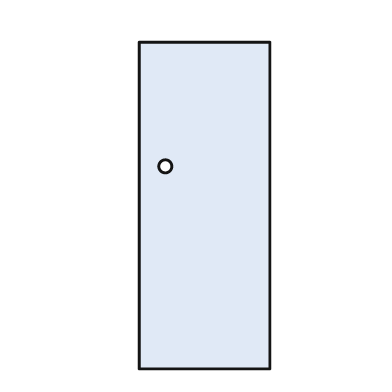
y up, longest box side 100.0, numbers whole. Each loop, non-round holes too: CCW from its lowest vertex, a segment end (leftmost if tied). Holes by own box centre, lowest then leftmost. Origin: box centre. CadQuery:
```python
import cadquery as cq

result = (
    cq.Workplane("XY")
    .moveTo(-20.0, -50.0)
    .lineTo(20.0, -50.0)
    .lineTo(20.0, 50.0)
    .lineTo(-20.0, 50.0)
    .close()
    .moveTo(-12.0, 12.0)
    .circle(2.0)
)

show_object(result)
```